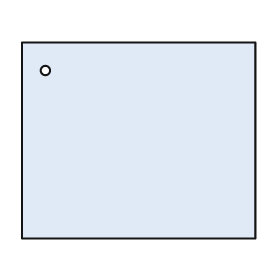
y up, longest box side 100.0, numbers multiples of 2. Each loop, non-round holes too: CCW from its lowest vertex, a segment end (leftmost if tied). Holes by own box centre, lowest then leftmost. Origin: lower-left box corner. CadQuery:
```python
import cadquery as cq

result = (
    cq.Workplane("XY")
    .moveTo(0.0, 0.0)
    .lineTo(100.0, 0.0)
    .lineTo(100.0, 84.0)
    .lineTo(0.0, 84.0)
    .close()
    .moveTo(10.0, 72.0)
    .circle(2.0)
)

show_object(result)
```